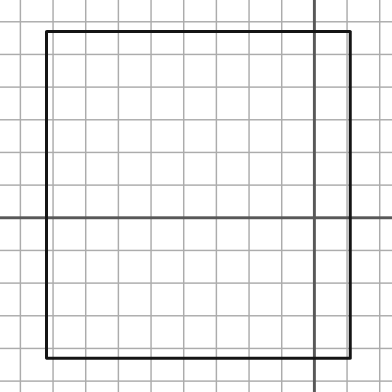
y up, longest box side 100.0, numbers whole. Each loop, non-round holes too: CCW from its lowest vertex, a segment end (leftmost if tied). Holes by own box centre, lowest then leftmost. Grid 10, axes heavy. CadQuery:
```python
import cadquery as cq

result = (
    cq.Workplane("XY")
    .moveTo(-82.0, -43.0)
    .lineTo(11.0, -43.0)
    .lineTo(11.0, 57.0)
    .lineTo(-82.0, 57.0)
    .close()
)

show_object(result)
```